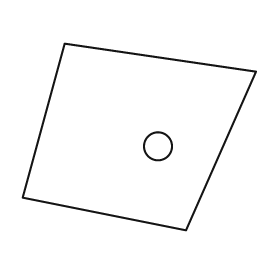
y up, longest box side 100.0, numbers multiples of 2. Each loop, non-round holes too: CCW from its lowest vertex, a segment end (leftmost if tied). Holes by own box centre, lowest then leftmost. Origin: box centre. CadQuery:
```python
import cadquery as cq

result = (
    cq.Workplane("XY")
    .moveTo(20.0, -40.0)
    .lineTo(50.0, 28.0)
    .lineTo(-32.0, 40.0)
    .lineTo(-50.0, -26.0)
    .close()
    .moveTo(8.0, -4.0)
    .circle(6.0)
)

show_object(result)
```